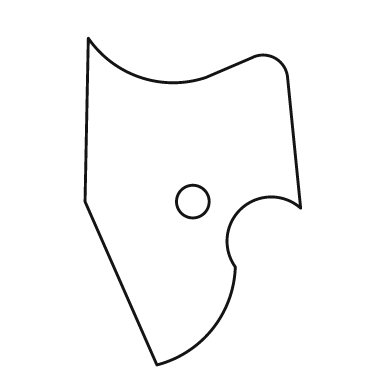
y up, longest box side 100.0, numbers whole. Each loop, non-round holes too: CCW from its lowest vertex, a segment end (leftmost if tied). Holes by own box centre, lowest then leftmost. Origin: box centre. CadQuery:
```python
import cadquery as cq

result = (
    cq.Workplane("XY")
    .moveTo(-11.0, -50.0)
    .threePointArc((6.0, -39.0), (13.0, -20.0))
    .threePointArc((15.0, -2.0), (33.0, -2.0))
    .lineTo(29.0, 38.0)
    .threePointArc((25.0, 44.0), (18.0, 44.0))
    .lineTo(4.0, 38.0)
    .threePointArc((-16.0, 38.0), (-32.0, 50.0))
    .lineTo(-33.0, 0.0)
    .close()
    .moveTo(0.0, 0.0)
    .circle(5.0)
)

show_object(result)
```